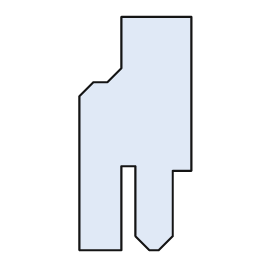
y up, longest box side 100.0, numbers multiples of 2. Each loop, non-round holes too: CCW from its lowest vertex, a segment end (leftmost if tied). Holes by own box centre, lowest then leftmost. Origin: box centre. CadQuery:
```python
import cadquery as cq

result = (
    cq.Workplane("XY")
    .moveTo(-24.0, -50.0)
    .lineTo(-6.0, -50.0)
    .lineTo(-6.0, -14.0)
    .lineTo(0.0, -14.0)
    .lineTo(0.0, -44.0)
    .lineTo(6.0, -50.0)
    .lineTo(10.0, -50.0)
    .lineTo(16.0, -44.0)
    .lineTo(16.0, -16.0)
    .lineTo(24.0, -16.0)
    .lineTo(24.0, 50.0)
    .lineTo(-6.0, 50.0)
    .lineTo(-6.0, 28.0)
    .lineTo(-12.0, 22.0)
    .lineTo(-18.0, 22.0)
    .lineTo(-24.0, 16.0)
    .close()
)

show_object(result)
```